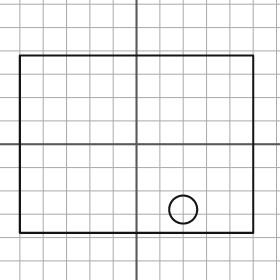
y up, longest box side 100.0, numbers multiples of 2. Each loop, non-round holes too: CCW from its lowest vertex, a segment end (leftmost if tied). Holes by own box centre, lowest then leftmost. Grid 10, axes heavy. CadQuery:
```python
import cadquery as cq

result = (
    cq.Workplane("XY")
    .moveTo(-50.0, -38.0)
    .lineTo(50.0, -38.0)
    .lineTo(50.0, 38.0)
    .lineTo(-50.0, 38.0)
    .close()
    .moveTo(20.0, -28.0)
    .circle(6.0)
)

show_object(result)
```